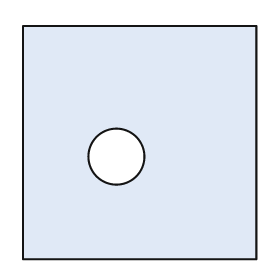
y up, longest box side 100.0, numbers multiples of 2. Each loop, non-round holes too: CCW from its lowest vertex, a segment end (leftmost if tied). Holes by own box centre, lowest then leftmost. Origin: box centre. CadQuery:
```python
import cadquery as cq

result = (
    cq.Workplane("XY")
    .moveTo(-50.0, -50.0)
    .lineTo(50.0, -50.0)
    .lineTo(50.0, 50.0)
    .lineTo(-50.0, 50.0)
    .close()
    .moveTo(-10.0, -6.0)
    .circle(12.0)
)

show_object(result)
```